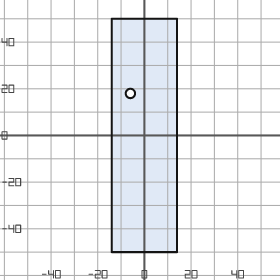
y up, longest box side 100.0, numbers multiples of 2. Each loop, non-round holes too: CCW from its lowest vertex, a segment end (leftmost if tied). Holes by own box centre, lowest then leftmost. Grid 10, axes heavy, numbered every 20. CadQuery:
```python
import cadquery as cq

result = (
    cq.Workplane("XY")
    .moveTo(-14.0, -50.0)
    .lineTo(14.0, -50.0)
    .lineTo(14.0, 50.0)
    .lineTo(-14.0, 50.0)
    .close()
    .moveTo(-6.0, 18.0)
    .circle(2.0)
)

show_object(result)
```